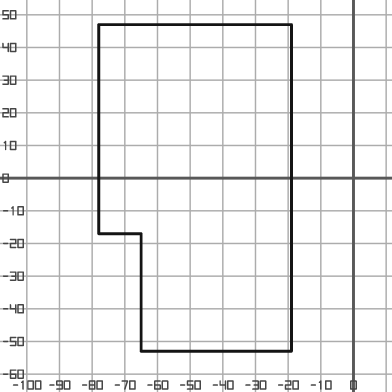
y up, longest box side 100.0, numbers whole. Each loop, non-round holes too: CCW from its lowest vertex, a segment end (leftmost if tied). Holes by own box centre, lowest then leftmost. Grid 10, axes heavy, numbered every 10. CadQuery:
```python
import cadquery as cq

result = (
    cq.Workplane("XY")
    .moveTo(-65.0, -53.0)
    .lineTo(-19.0, -53.0)
    .lineTo(-19.0, 47.0)
    .lineTo(-78.0, 47.0)
    .lineTo(-78.0, -17.0)
    .lineTo(-65.0, -17.0)
    .close()
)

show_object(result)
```